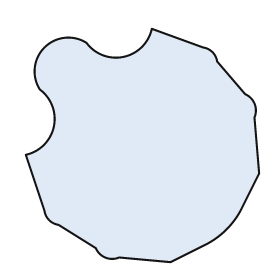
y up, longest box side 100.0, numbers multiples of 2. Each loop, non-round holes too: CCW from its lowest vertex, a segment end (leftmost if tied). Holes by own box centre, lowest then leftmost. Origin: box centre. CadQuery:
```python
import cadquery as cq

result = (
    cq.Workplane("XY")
    .moveTo(12.0, -50.0)
    .lineTo(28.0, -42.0)
    .threePointArc((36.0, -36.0), (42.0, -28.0))
    .lineTo(50.0, -12.0)
    .lineTo(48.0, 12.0)
    .threePointArc((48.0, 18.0), (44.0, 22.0))
    .lineTo(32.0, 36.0)
    .threePointArc((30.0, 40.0), (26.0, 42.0))
    .lineTo(4.0, 50.0)
    .threePointArc((-8.0, 38.0), (-24.0, 44.0))
    .threePointArc((-42.0, 42.0), (-44.0, 24.0))
    .threePointArc((-38.0, 8.0), (-50.0, -4.0))
    .lineTo(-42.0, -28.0)
    .threePointArc((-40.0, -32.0), (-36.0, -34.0))
    .lineTo(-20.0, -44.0)
    .threePointArc((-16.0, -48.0), (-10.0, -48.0))
    .close()
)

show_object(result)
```